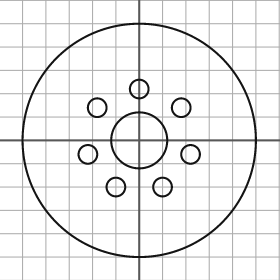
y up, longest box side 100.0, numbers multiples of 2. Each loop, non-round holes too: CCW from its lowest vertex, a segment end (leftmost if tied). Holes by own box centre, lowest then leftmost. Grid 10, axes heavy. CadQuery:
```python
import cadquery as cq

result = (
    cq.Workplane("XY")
    .moveTo(0.0, 0.0)
    .circle(50.0)
    .moveTo(-10.0, -20.0)
    .circle(4.0)
    .moveTo(10.0, -20.0)
    .circle(4.0)
    .moveTo(-22.0, -6.0)
    .circle(4.0)
    .moveTo(22.0, -6.0)
    .circle(4.0)
    .moveTo(0.0, 0.0)
    .circle(12.0)
    .moveTo(-18.0, 14.0)
    .circle(4.0)
    .moveTo(18.0, 14.0)
    .circle(4.0)
    .moveTo(0.0, 22.0)
    .circle(4.0)
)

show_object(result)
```